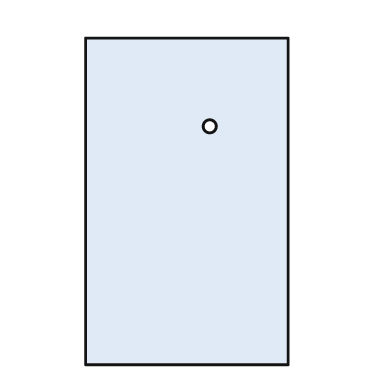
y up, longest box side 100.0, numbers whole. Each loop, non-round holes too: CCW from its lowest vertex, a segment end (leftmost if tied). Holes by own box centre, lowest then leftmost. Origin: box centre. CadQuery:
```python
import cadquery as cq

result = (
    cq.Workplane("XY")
    .moveTo(-31.0, -50.0)
    .lineTo(31.0, -50.0)
    .lineTo(31.0, 50.0)
    .lineTo(-31.0, 50.0)
    .close()
    .moveTo(7.0, 23.0)
    .circle(2.0)
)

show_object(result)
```